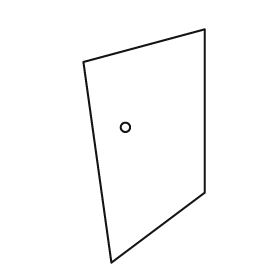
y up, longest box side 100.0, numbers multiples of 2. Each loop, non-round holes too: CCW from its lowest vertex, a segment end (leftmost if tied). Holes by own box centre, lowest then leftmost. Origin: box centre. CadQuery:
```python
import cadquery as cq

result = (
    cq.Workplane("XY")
    .moveTo(-14.0, -50.0)
    .lineTo(26.0, -20.0)
    .lineTo(26.0, 50.0)
    .lineTo(-26.0, 36.0)
    .close()
    .moveTo(-8.0, 8.0)
    .circle(2.0)
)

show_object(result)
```